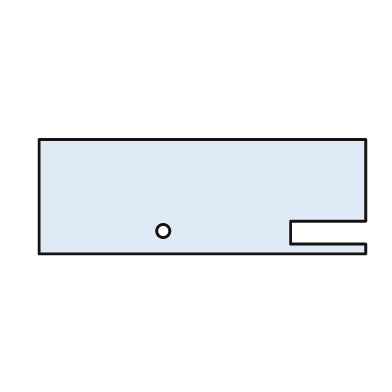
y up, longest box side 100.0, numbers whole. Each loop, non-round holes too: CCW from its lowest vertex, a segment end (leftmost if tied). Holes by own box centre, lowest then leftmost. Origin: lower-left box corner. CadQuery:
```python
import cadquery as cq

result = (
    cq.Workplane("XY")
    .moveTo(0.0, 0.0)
    .lineTo(100.0, 0.0)
    .lineTo(100.0, 3.0)
    .lineTo(77.0, 3.0)
    .lineTo(77.0, 10.0)
    .lineTo(100.0, 10.0)
    .lineTo(100.0, 35.0)
    .lineTo(0.0, 35.0)
    .close()
    .moveTo(38.0, 7.0)
    .circle(2.0)
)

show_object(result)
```